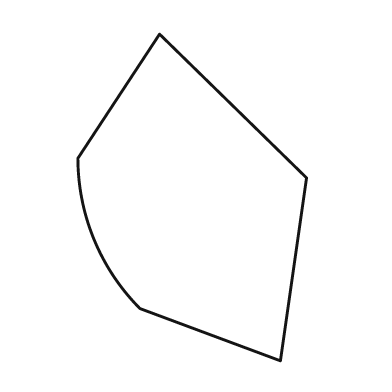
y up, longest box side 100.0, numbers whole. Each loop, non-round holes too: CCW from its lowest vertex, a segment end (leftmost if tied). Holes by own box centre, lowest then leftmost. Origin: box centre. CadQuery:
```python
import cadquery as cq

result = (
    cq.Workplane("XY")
    .moveTo(27.0, -50.0)
    .lineTo(35.0, 6.0)
    .lineTo(-10.0, 50.0)
    .lineTo(-35.0, 12.0)
    .threePointArc((-30.0, -13.0), (-16.0, -34.0))
    .close()
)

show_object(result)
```